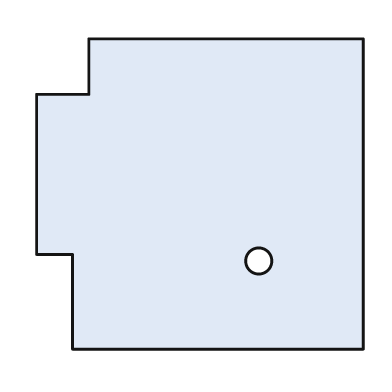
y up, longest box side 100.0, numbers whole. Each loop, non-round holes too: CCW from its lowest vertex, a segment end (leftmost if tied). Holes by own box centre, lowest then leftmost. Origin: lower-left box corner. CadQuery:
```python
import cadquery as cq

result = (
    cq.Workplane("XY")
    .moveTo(11.0, 0.0)
    .lineTo(100.0, 0.0)
    .lineTo(100.0, 95.0)
    .lineTo(16.0, 95.0)
    .lineTo(16.0, 78.0)
    .lineTo(0.0, 78.0)
    .lineTo(0.0, 29.0)
    .lineTo(11.0, 29.0)
    .close()
    .moveTo(68.0, 27.0)
    .circle(4.0)
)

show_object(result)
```